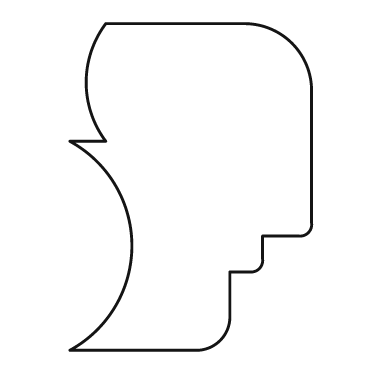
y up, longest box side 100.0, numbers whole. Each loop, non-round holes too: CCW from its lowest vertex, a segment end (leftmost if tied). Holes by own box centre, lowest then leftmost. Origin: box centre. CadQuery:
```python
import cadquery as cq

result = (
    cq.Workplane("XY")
    .moveTo(-37.0, -50.0)
    .lineTo(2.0, -50.0)
    .threePointArc((9.0, -47.0), (12.0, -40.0))
    .lineTo(12.0, -26.0)
    .lineTo(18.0, -26.0)
    .threePointArc((21.0, -25.0), (22.0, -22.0))
    .lineTo(22.0, -15.0)
    .lineTo(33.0, -15.0)
    .threePointArc((36.0, -14.0), (37.0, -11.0))
    .lineTo(37.0, 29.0)
    .threePointArc((31.0, 44.0), (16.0, 50.0))
    .lineTo(-26.0, 50.0)
    .threePointArc((-32.0, 32.0), (-26.0, 14.0))
    .lineTo(-37.0, 14.0)
    .threePointArc((-18.0, -18.0), (-37.0, -50.0))
    .close()
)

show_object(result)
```